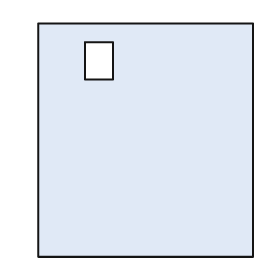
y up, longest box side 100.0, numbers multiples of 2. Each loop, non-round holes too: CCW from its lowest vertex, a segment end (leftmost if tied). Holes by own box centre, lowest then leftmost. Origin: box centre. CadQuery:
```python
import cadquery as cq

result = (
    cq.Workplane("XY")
    .moveTo(-46.0, -50.0)
    .lineTo(46.0, -50.0)
    .lineTo(46.0, 50.0)
    .lineTo(-46.0, 50.0)
    .close()
    .moveTo(-26.0, 26.0)
    .lineTo(-14.0, 26.0)
    .lineTo(-14.0, 42.0)
    .lineTo(-26.0, 42.0)
    .close()
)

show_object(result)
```